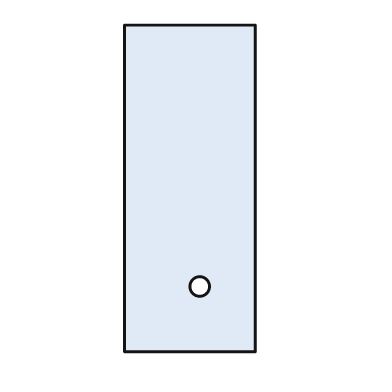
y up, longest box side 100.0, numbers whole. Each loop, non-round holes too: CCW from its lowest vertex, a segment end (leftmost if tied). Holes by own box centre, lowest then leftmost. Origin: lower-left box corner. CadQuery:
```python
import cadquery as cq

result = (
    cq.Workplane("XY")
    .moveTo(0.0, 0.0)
    .lineTo(40.0, 0.0)
    .lineTo(40.0, 100.0)
    .lineTo(0.0, 100.0)
    .close()
    .moveTo(23.0, 20.0)
    .circle(3.0)
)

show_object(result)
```